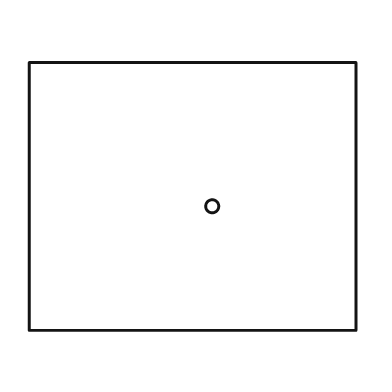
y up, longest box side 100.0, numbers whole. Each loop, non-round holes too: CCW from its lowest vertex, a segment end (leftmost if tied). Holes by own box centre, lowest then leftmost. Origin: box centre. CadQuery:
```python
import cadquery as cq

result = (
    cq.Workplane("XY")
    .moveTo(-50.0, -41.0)
    .lineTo(50.0, -41.0)
    .lineTo(50.0, 41.0)
    .lineTo(-50.0, 41.0)
    .close()
    .moveTo(6.0, -3.0)
    .circle(2.0)
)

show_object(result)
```